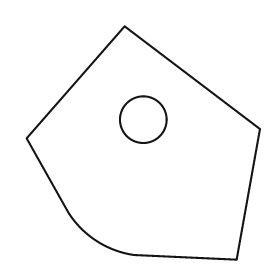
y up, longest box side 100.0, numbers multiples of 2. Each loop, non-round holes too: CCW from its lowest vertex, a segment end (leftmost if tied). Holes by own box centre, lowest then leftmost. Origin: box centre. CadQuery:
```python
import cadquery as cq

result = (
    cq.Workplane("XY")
    .moveTo(40.0, -50.0)
    .lineTo(50.0, 6.0)
    .lineTo(-8.0, 50.0)
    .lineTo(-50.0, 2.0)
    .lineTo(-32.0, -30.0)
    .threePointArc((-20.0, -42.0), (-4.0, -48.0))
    .close()
    .moveTo(0.0, 10.0)
    .circle(10.0)
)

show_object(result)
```